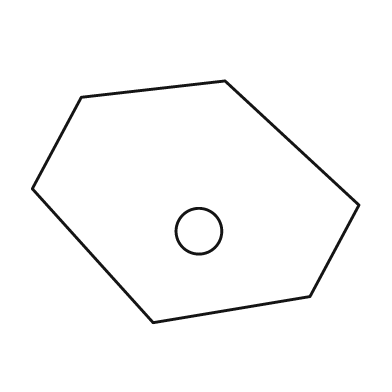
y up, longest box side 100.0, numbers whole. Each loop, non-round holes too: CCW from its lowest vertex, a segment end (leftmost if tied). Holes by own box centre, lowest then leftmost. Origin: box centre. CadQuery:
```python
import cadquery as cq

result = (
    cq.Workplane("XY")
    .moveTo(-13.0, -37.0)
    .lineTo(35.0, -29.0)
    .lineTo(50.0, -1.0)
    .lineTo(9.0, 37.0)
    .lineTo(-35.0, 32.0)
    .lineTo(-50.0, 4.0)
    .close()
    .moveTo(1.0, -9.0)
    .circle(7.0)
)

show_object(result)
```